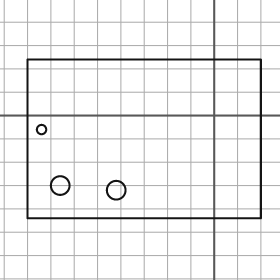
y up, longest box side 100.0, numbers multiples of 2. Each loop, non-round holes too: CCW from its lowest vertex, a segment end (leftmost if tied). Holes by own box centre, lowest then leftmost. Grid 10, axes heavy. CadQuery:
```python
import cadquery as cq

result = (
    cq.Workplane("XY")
    .moveTo(-80.0, -44.0)
    .lineTo(20.0, -44.0)
    .lineTo(20.0, 24.0)
    .lineTo(-80.0, 24.0)
    .close()
    .moveTo(-42.0, -32.0)
    .circle(4.0)
    .moveTo(-66.0, -30.0)
    .circle(4.0)
    .moveTo(-74.0, -6.0)
    .circle(2.0)
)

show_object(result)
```